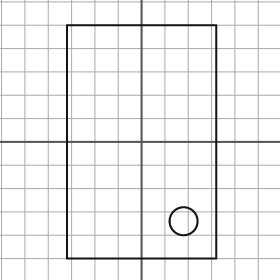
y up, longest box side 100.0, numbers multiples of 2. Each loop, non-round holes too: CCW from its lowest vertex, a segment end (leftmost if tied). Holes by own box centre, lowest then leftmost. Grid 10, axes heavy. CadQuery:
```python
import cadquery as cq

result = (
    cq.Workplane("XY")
    .moveTo(-32.0, -50.0)
    .lineTo(32.0, -50.0)
    .lineTo(32.0, 50.0)
    .lineTo(-32.0, 50.0)
    .close()
    .moveTo(18.0, -34.0)
    .circle(6.0)
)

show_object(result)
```